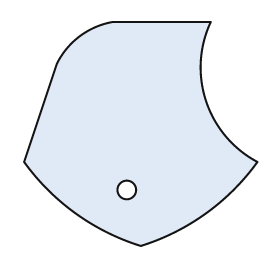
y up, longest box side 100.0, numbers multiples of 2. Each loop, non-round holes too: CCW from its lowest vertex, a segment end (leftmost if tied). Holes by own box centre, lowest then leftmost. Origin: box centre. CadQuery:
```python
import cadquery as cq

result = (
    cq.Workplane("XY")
    .moveTo(0.0, -48.0)
    .threePointArc((28.0, -34.0), (50.0, -12.0))
    .threePointArc((28.0, 14.0), (30.0, 48.0))
    .lineTo(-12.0, 48.0)
    .threePointArc((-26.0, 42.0), (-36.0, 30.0))
    .lineTo(-50.0, -12.0)
    .threePointArc((-28.0, -34.0), (0.0, -48.0))
    .close()
    .moveTo(-6.0, -24.0)
    .circle(4.0)
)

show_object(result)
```